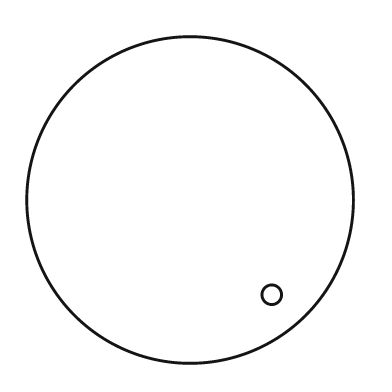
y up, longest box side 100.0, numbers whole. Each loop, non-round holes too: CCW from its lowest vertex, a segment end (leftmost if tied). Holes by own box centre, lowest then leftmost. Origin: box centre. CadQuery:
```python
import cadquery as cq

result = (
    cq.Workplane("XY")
    .moveTo(0.0, 0.0)
    .circle(50.0)
    .moveTo(25.0, -29.0)
    .circle(3.0)
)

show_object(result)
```